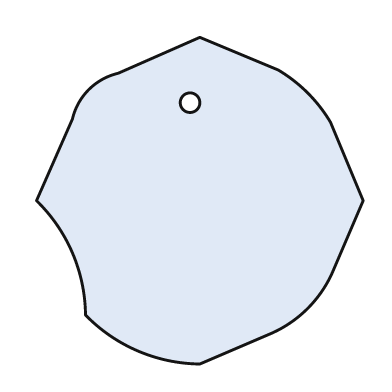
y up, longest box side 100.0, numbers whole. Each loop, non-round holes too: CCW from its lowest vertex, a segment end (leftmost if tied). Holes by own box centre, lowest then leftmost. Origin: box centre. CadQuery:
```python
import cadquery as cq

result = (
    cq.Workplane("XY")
    .moveTo(0.0, -50.0)
    .lineTo(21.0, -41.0)
    .threePointArc((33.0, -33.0), (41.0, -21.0))
    .lineTo(50.0, 0.0)
    .lineTo(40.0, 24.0)
    .threePointArc((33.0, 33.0), (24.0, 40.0))
    .lineTo(0.0, 50.0)
    .lineTo(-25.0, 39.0)
    .threePointArc((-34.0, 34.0), (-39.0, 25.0))
    .lineTo(-50.0, 0.0)
    .threePointArc((-39.0, -16.0), (-35.0, -35.0))
    .threePointArc((-19.0, -46.0), (0.0, -50.0))
    .close()
    .moveTo(-3.0, 30.0)
    .circle(3.0)
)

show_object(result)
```